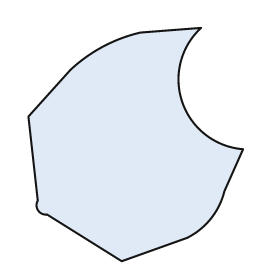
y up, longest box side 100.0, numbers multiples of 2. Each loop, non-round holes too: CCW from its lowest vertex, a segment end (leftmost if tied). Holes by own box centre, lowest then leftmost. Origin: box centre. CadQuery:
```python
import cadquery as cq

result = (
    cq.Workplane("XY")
    .moveTo(-6.0, -50.0)
    .lineTo(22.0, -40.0)
    .threePointArc((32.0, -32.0), (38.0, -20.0))
    .lineTo(46.0, -2.0)
    .threePointArc((20.0, 18.0), (28.0, 50.0))
    .lineTo(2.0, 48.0)
    .threePointArc((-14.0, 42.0), (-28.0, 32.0))
    .lineTo(-46.0, 12.0)
    .lineTo(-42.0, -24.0)
    .threePointArc((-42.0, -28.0), (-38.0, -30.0))
    .close()
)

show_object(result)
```